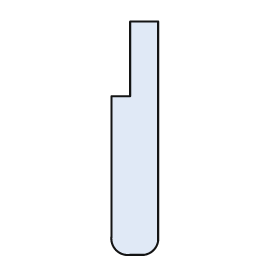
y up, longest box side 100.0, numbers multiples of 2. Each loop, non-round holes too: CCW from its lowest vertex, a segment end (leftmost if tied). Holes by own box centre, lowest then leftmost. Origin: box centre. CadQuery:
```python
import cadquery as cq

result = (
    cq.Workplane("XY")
    .moveTo(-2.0, -50.0)
    .lineTo(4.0, -50.0)
    .threePointArc((8.0, -48.0), (10.0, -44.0))
    .lineTo(10.0, 50.0)
    .lineTo(-2.0, 50.0)
    .lineTo(-2.0, 18.0)
    .lineTo(-10.0, 18.0)
    .lineTo(-10.0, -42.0)
    .threePointArc((-8.0, -48.0), (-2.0, -50.0))
    .close()
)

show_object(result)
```